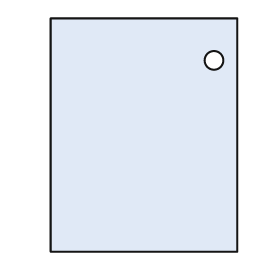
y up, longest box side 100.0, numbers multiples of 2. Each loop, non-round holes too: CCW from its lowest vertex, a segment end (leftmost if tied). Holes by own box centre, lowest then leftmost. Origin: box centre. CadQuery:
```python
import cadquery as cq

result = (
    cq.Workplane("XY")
    .moveTo(-40.0, -50.0)
    .lineTo(40.0, -50.0)
    .lineTo(40.0, 50.0)
    .lineTo(-40.0, 50.0)
    .close()
    .moveTo(30.0, 32.0)
    .circle(4.0)
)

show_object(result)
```